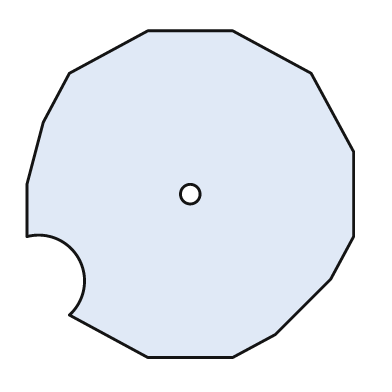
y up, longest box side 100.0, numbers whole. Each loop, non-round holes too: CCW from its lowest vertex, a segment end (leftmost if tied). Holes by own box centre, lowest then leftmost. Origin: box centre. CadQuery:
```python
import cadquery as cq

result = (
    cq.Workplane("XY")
    .moveTo(-13.0, -50.0)
    .lineTo(13.0, -50.0)
    .lineTo(26.0, -43.0)
    .lineTo(43.0, -26.0)
    .lineTo(50.0, -13.0)
    .lineTo(50.0, 13.0)
    .lineTo(37.0, 37.0)
    .lineTo(13.0, 50.0)
    .lineTo(-13.0, 50.0)
    .lineTo(-37.0, 37.0)
    .lineTo(-45.0, 22.0)
    .lineTo(-50.0, 3.0)
    .lineTo(-50.0, -13.0)
    .threePointArc((-34.0, -20.0), (-37.0, -37.0))
    .close()
    .moveTo(0.0, 0.0)
    .circle(3.0)
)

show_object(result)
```